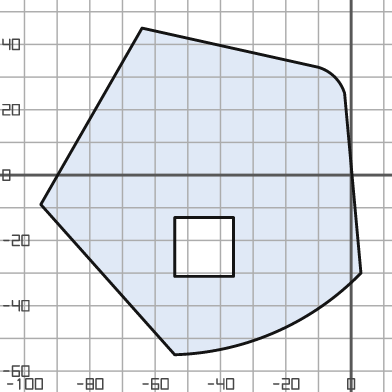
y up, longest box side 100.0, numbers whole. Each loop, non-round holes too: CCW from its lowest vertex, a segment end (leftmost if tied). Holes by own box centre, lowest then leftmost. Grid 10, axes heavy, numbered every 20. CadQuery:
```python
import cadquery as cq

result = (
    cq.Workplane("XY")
    .moveTo(-54.0, -55.0)
    .threePointArc((-23.0, -48.0), (3.0, -30.0))
    .lineTo(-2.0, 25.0)
    .threePointArc((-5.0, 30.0), (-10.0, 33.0))
    .lineTo(-64.0, 45.0)
    .lineTo(-95.0, -9.0)
    .close()
    .moveTo(-54.0, -31.0)
    .lineTo(-36.0, -31.0)
    .lineTo(-36.0, -13.0)
    .lineTo(-54.0, -13.0)
    .close()
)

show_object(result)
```